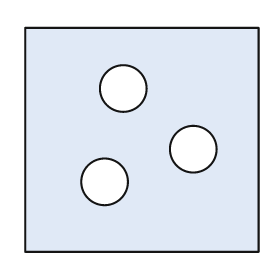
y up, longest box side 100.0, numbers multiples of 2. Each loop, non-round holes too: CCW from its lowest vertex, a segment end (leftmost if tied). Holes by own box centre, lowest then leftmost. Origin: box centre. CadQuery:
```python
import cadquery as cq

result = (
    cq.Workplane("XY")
    .moveTo(-50.0, -48.0)
    .lineTo(50.0, -48.0)
    .lineTo(50.0, 48.0)
    .lineTo(-50.0, 48.0)
    .close()
    .moveTo(-16.0, -18.0)
    .circle(10.0)
    .moveTo(22.0, -4.0)
    .circle(10.0)
    .moveTo(-8.0, 22.0)
    .circle(10.0)
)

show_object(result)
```